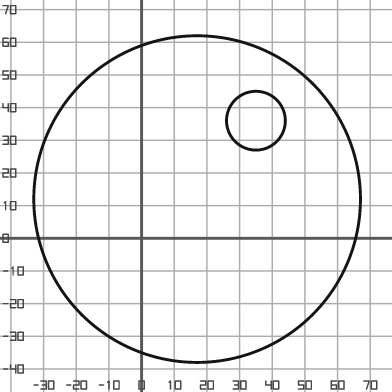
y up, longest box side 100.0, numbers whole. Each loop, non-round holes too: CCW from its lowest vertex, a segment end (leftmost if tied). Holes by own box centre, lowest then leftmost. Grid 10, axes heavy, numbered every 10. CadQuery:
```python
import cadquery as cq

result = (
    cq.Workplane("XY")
    .moveTo(17.0, 12.0)
    .circle(50.0)
    .moveTo(35.0, 36.0)
    .circle(9.0)
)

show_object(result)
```